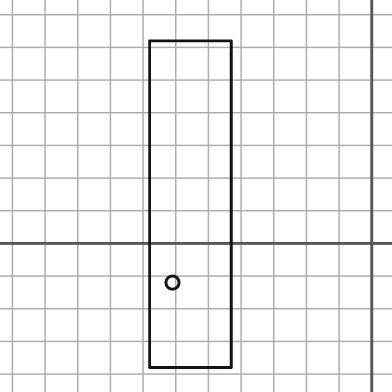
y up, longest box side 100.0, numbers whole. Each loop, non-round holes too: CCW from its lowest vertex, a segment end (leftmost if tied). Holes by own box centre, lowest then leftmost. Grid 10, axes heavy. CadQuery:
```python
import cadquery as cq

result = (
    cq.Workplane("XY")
    .moveTo(-68.0, -38.0)
    .lineTo(-43.0, -38.0)
    .lineTo(-43.0, 62.0)
    .lineTo(-68.0, 62.0)
    .close()
    .moveTo(-61.0, -12.0)
    .circle(2.0)
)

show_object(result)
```